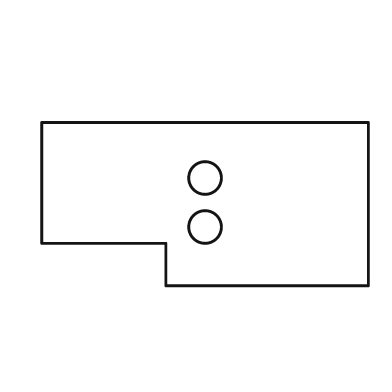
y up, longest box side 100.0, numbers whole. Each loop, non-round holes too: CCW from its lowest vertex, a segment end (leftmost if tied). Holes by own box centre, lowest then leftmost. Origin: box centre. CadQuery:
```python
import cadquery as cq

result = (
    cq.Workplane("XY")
    .moveTo(-12.0, -25.0)
    .lineTo(50.0, -25.0)
    .lineTo(50.0, 25.0)
    .lineTo(-50.0, 25.0)
    .lineTo(-50.0, -12.0)
    .lineTo(-12.0, -12.0)
    .close()
    .moveTo(0.0, -7.0)
    .circle(5.0)
    .moveTo(0.0, 8.0)
    .circle(5.0)
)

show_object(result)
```